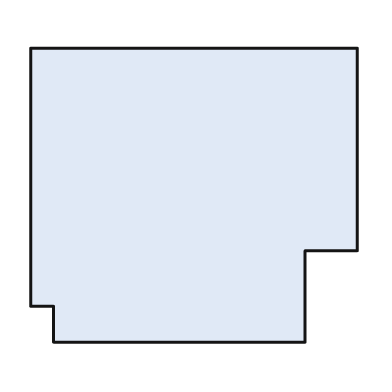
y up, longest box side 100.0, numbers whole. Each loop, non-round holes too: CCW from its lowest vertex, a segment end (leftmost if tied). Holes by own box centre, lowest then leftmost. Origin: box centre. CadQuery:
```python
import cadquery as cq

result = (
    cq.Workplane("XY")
    .moveTo(-43.0, -45.0)
    .lineTo(34.0, -45.0)
    .lineTo(34.0, -17.0)
    .lineTo(50.0, -17.0)
    .lineTo(50.0, 45.0)
    .lineTo(-50.0, 45.0)
    .lineTo(-50.0, -34.0)
    .lineTo(-43.0, -34.0)
    .close()
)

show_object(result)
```